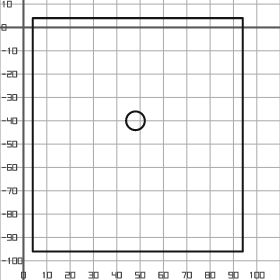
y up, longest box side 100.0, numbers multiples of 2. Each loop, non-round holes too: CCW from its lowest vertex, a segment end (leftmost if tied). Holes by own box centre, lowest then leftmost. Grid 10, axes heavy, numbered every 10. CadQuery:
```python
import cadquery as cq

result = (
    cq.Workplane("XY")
    .moveTo(4.0, -96.0)
    .lineTo(94.0, -96.0)
    .lineTo(94.0, 4.0)
    .lineTo(4.0, 4.0)
    .close()
    .moveTo(48.0, -40.0)
    .circle(4.0)
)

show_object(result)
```